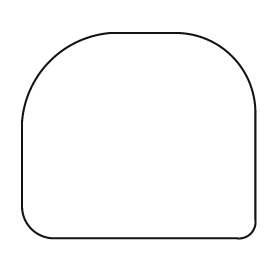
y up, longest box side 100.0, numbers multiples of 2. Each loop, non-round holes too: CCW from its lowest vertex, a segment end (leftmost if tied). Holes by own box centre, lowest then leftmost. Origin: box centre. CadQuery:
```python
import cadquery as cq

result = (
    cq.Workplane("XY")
    .moveTo(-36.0, -44.0)
    .lineTo(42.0, -44.0)
    .threePointArc((48.0, -42.0), (50.0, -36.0))
    .lineTo(50.0, 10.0)
    .threePointArc((40.0, 34.0), (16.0, 44.0))
    .lineTo(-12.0, 44.0)
    .threePointArc((-38.0, 32.0), (-50.0, 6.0))
    .lineTo(-50.0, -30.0)
    .threePointArc((-46.0, -40.0), (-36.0, -44.0))
    .close()
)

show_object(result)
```